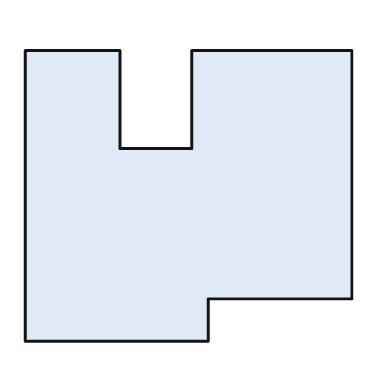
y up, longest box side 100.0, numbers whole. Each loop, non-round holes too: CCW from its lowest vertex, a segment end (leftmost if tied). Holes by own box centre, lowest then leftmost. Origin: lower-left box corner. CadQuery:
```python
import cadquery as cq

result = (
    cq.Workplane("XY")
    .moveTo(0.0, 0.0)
    .lineTo(56.0, 0.0)
    .lineTo(56.0, 13.0)
    .lineTo(100.0, 13.0)
    .lineTo(100.0, 89.0)
    .lineTo(51.0, 89.0)
    .lineTo(51.0, 59.0)
    .lineTo(29.0, 59.0)
    .lineTo(29.0, 89.0)
    .lineTo(0.0, 89.0)
    .close()
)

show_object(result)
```